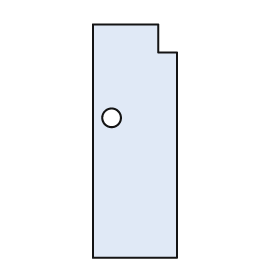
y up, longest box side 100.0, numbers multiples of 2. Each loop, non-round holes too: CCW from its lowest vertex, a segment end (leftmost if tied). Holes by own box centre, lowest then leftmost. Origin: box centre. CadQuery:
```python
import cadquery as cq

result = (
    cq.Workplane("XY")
    .moveTo(-18.0, -50.0)
    .lineTo(18.0, -50.0)
    .lineTo(18.0, 38.0)
    .lineTo(10.0, 38.0)
    .lineTo(10.0, 50.0)
    .lineTo(-18.0, 50.0)
    .close()
    .moveTo(-10.0, 10.0)
    .circle(4.0)
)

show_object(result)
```